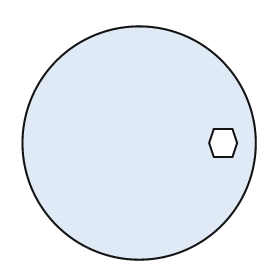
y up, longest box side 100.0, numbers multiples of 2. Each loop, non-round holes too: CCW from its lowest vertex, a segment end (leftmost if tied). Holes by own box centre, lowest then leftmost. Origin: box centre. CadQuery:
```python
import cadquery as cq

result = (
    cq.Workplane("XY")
    .moveTo(0.0, 0.0)
    .circle(50.0)
    .moveTo(32.0, -6.0)
    .lineTo(40.0, -6.0)
    .lineTo(42.0, 0.0)
    .lineTo(40.0, 6.0)
    .lineTo(32.0, 6.0)
    .lineTo(30.0, 0.0)
    .close()
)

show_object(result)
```